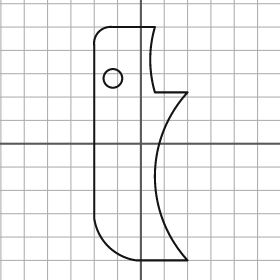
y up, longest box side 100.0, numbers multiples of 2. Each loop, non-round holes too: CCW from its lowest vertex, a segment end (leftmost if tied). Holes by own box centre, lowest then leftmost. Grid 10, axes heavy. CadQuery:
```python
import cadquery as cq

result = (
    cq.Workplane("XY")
    .moveTo(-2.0, -50.0)
    .lineTo(20.0, -50.0)
    .threePointArc((6.0, -14.0), (20.0, 22.0))
    .lineTo(6.0, 22.0)
    .threePointArc((4.0, 36.0), (6.0, 50.0))
    .lineTo(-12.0, 50.0)
    .threePointArc((-18.0, 48.0), (-20.0, 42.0))
    .lineTo(-20.0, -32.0)
    .threePointArc((-14.0, -44.0), (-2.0, -50.0))
    .close()
    .moveTo(-12.0, 28.0)
    .circle(4.0)
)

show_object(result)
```